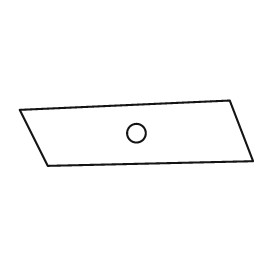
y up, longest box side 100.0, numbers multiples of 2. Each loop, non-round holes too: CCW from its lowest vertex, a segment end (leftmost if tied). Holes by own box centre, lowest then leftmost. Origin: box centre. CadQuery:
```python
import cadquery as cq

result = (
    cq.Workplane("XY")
    .moveTo(-38.0, -14.0)
    .lineTo(50.0, -12.0)
    .lineTo(40.0, 14.0)
    .lineTo(-50.0, 10.0)
    .close()
    .moveTo(0.0, 0.0)
    .circle(4.0)
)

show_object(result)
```